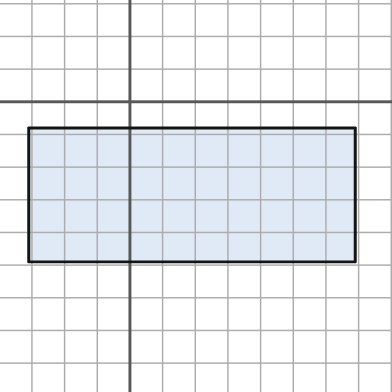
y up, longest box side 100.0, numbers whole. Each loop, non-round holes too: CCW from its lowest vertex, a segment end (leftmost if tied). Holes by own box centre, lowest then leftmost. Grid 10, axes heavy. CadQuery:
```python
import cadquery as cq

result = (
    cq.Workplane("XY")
    .moveTo(-31.0, -49.0)
    .lineTo(69.0, -49.0)
    .lineTo(69.0, -8.0)
    .lineTo(-31.0, -8.0)
    .close()
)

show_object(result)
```